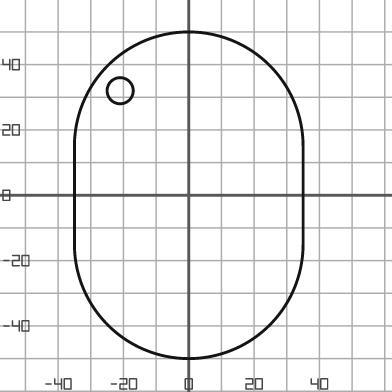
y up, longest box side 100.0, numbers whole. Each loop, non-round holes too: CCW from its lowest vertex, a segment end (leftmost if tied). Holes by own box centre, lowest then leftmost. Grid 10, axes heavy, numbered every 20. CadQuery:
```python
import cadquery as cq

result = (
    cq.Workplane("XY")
    .moveTo(-35.0, -15.0)
    .threePointArc((0.0, -50.0), (35.0, -15.0))
    .lineTo(35.0, 15.0)
    .threePointArc((0.0, 50.0), (-35.0, 15.0))
    .close()
    .moveTo(-21.0, 32.0)
    .circle(4.0)
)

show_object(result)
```